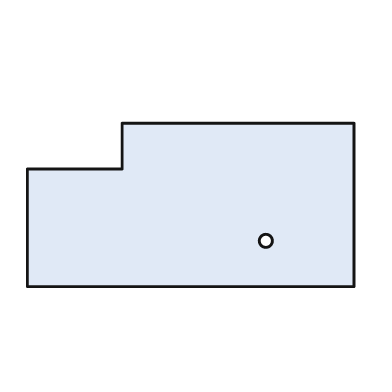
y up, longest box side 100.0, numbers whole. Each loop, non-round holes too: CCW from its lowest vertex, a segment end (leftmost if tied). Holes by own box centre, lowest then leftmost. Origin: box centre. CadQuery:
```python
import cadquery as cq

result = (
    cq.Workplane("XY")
    .moveTo(-50.0, -25.0)
    .lineTo(50.0, -25.0)
    .lineTo(50.0, 25.0)
    .lineTo(-21.0, 25.0)
    .lineTo(-21.0, 11.0)
    .lineTo(-50.0, 11.0)
    .close()
    .moveTo(23.0, -11.0)
    .circle(2.0)
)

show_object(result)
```